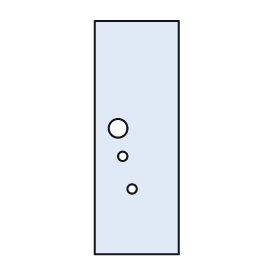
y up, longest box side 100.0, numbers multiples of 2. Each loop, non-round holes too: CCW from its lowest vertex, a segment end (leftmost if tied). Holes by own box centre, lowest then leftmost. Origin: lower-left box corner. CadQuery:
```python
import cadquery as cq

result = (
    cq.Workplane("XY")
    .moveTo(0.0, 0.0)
    .lineTo(36.0, 0.0)
    .lineTo(36.0, 100.0)
    .lineTo(0.0, 100.0)
    .close()
    .moveTo(16.0, 28.0)
    .circle(2.0)
    .moveTo(12.0, 42.0)
    .circle(2.0)
    .moveTo(10.0, 54.0)
    .circle(4.0)
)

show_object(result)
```